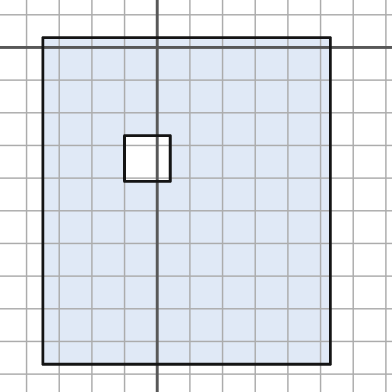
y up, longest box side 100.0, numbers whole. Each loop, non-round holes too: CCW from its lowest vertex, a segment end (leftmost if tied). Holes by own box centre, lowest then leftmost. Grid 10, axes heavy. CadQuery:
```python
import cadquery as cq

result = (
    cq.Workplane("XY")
    .moveTo(-35.0, -97.0)
    .lineTo(53.0, -97.0)
    .lineTo(53.0, 3.0)
    .lineTo(-35.0, 3.0)
    .close()
    .moveTo(-10.0, -41.0)
    .lineTo(4.0, -41.0)
    .lineTo(4.0, -27.0)
    .lineTo(-10.0, -27.0)
    .close()
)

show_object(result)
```